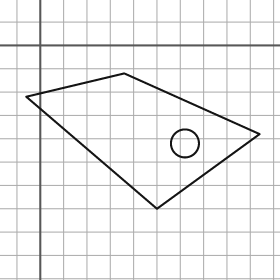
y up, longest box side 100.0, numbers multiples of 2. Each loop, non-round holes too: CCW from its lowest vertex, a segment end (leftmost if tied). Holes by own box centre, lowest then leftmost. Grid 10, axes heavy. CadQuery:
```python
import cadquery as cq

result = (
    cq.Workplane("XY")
    .moveTo(50.0, -70.0)
    .lineTo(94.0, -38.0)
    .lineTo(36.0, -12.0)
    .lineTo(-6.0, -22.0)
    .close()
    .moveTo(62.0, -42.0)
    .circle(6.0)
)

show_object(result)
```